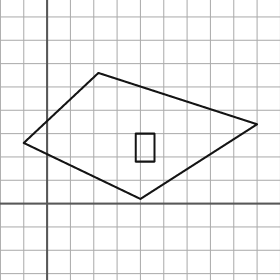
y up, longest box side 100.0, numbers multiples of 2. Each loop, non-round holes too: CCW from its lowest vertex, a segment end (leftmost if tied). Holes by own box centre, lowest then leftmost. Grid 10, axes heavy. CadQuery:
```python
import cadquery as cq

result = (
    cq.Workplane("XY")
    .moveTo(40.0, 2.0)
    .lineTo(90.0, 34.0)
    .lineTo(22.0, 56.0)
    .lineTo(-10.0, 26.0)
    .close()
    .moveTo(38.0, 18.0)
    .lineTo(46.0, 18.0)
    .lineTo(46.0, 30.0)
    .lineTo(38.0, 30.0)
    .close()
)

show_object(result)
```